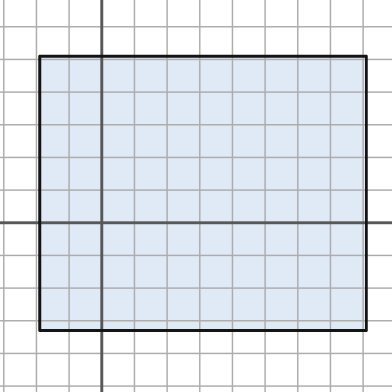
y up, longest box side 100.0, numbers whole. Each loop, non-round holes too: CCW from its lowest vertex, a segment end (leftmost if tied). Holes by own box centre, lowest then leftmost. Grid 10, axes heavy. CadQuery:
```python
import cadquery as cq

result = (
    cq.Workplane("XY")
    .moveTo(-19.0, -33.0)
    .lineTo(81.0, -33.0)
    .lineTo(81.0, 51.0)
    .lineTo(-19.0, 51.0)
    .close()
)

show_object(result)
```